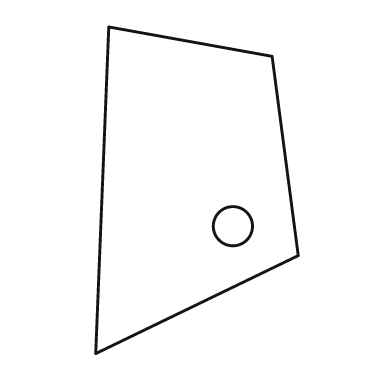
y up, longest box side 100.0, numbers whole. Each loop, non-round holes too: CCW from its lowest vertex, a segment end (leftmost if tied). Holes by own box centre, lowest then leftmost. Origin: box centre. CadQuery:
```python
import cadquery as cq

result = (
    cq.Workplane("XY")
    .moveTo(-31.0, -50.0)
    .lineTo(31.0, -20.0)
    .lineTo(23.0, 41.0)
    .lineTo(-27.0, 50.0)
    .close()
    .moveTo(11.0, -11.0)
    .circle(6.0)
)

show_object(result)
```